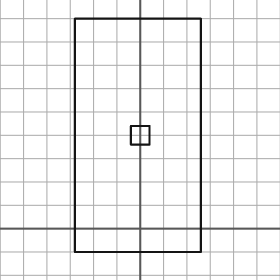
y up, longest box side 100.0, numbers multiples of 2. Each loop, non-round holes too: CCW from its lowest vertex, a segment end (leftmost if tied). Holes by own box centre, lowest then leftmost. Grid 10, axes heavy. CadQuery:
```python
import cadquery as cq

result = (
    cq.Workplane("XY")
    .moveTo(-28.0, -10.0)
    .lineTo(26.0, -10.0)
    .lineTo(26.0, 90.0)
    .lineTo(-28.0, 90.0)
    .close()
    .moveTo(-4.0, 36.0)
    .lineTo(4.0, 36.0)
    .lineTo(4.0, 44.0)
    .lineTo(-4.0, 44.0)
    .close()
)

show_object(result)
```